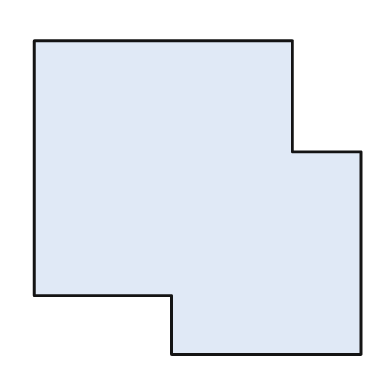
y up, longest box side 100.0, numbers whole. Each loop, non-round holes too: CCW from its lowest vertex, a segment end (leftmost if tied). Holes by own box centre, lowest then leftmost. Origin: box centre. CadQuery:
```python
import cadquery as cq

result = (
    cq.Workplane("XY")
    .moveTo(-8.0, -48.0)
    .lineTo(50.0, -48.0)
    .lineTo(50.0, 14.0)
    .lineTo(29.0, 14.0)
    .lineTo(29.0, 48.0)
    .lineTo(-50.0, 48.0)
    .lineTo(-50.0, -30.0)
    .lineTo(-8.0, -30.0)
    .close()
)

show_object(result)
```